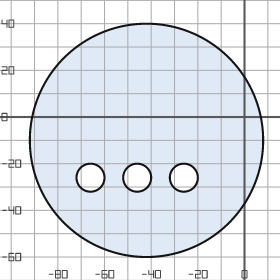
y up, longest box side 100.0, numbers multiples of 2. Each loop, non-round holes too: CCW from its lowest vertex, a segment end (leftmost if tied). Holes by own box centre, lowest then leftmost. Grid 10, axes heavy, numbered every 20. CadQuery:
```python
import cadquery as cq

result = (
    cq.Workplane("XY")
    .moveTo(-42.0, -10.0)
    .circle(50.0)
    .moveTo(-66.0, -26.0)
    .circle(6.0)
    .moveTo(-46.0, -26.0)
    .circle(6.0)
    .moveTo(-26.0, -26.0)
    .circle(6.0)
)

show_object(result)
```